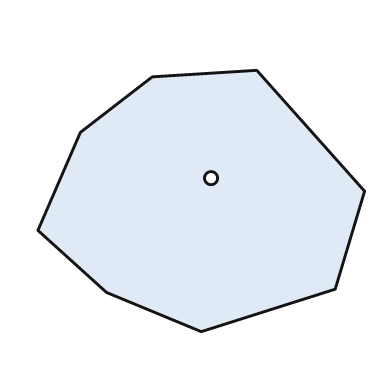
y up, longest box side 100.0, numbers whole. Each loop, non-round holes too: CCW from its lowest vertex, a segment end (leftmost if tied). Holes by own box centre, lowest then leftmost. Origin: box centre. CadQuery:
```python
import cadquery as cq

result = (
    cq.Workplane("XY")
    .moveTo(0.0, -40.0)
    .lineTo(41.0, -27.0)
    .lineTo(50.0, 3.0)
    .lineTo(17.0, 40.0)
    .lineTo(-15.0, 38.0)
    .lineTo(-37.0, 21.0)
    .lineTo(-50.0, -9.0)
    .lineTo(-29.0, -28.0)
    .close()
    .moveTo(3.0, 7.0)
    .circle(2.0)
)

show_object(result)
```